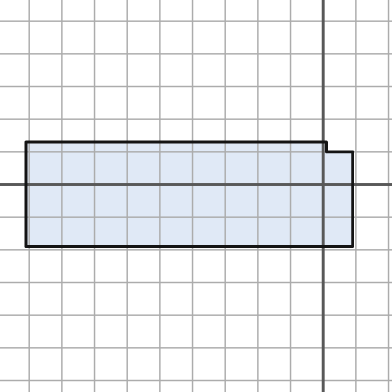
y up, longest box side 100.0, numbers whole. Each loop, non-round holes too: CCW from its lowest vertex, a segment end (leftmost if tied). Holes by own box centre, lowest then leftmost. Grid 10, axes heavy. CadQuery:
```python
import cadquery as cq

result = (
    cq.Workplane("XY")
    .moveTo(-91.0, -19.0)
    .lineTo(9.0, -19.0)
    .lineTo(9.0, 10.0)
    .lineTo(1.0, 10.0)
    .lineTo(1.0, 13.0)
    .lineTo(-91.0, 13.0)
    .close()
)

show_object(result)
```